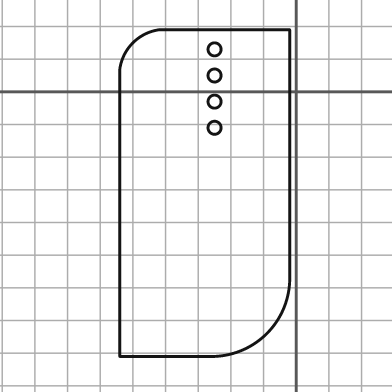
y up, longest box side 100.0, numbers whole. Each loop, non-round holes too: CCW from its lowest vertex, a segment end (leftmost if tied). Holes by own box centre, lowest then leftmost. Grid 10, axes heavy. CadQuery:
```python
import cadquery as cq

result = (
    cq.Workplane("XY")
    .moveTo(-54.0, -81.0)
    .lineTo(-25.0, -81.0)
    .threePointArc((-9.0, -74.0), (-2.0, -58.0))
    .lineTo(-2.0, 19.0)
    .lineTo(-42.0, 19.0)
    .threePointArc((-50.0, 15.0), (-54.0, 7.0))
    .close()
    .moveTo(-25.0, -11.0)
    .circle(2.0)
    .moveTo(-25.0, -3.0)
    .circle(2.0)
    .moveTo(-25.0, 5.0)
    .circle(2.0)
    .moveTo(-25.0, 13.0)
    .circle(2.0)
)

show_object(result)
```